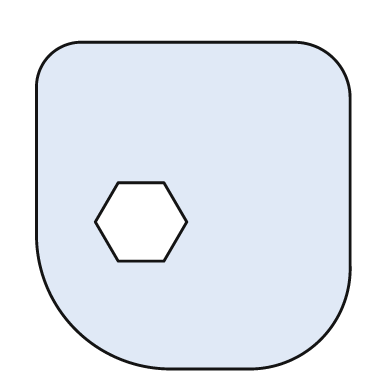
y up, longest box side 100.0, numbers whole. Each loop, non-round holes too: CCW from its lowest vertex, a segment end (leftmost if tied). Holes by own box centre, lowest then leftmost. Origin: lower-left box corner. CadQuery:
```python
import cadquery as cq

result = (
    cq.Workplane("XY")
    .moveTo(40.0, 0.0)
    .lineTo(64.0, 0.0)
    .threePointArc((87.0, 9.0), (96.0, 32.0))
    .lineTo(96.0, 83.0)
    .threePointArc((91.0, 95.0), (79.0, 100.0))
    .lineTo(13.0, 100.0)
    .threePointArc((4.0, 96.0), (0.0, 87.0))
    .lineTo(0.0, 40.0)
    .threePointArc((12.0, 12.0), (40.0, 0.0))
    .close()
    .moveTo(25.0, 33.0)
    .lineTo(39.0, 33.0)
    .lineTo(46.0, 45.0)
    .lineTo(39.0, 57.0)
    .lineTo(25.0, 57.0)
    .lineTo(18.0, 45.0)
    .close()
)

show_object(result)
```